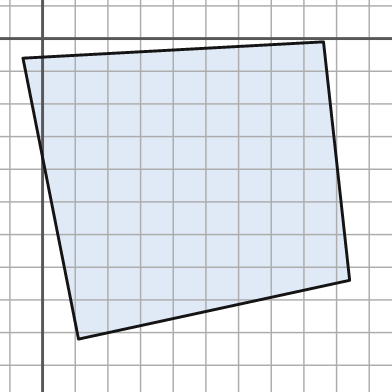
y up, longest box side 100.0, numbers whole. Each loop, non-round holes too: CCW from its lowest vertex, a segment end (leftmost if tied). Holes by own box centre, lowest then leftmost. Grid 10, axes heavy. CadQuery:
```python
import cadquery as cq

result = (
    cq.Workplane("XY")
    .moveTo(11.0, -92.0)
    .lineTo(94.0, -74.0)
    .lineTo(86.0, -1.0)
    .lineTo(-6.0, -6.0)
    .close()
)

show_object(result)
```